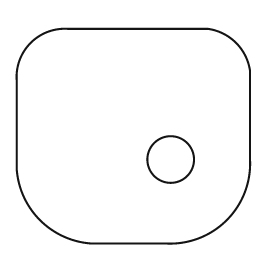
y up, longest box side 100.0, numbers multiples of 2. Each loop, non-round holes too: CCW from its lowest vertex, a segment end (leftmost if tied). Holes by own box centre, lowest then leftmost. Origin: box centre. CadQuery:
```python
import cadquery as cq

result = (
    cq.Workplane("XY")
    .moveTo(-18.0, -46.0)
    .lineTo(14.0, -46.0)
    .threePointArc((40.0, -36.0), (50.0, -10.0))
    .lineTo(50.0, 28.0)
    .threePointArc((44.0, 40.0), (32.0, 46.0))
    .lineTo(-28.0, 46.0)
    .threePointArc((-44.0, 40.0), (-50.0, 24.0))
    .lineTo(-50.0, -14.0)
    .threePointArc((-40.0, -36.0), (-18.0, -46.0))
    .close()
    .moveTo(16.0, -10.0)
    .circle(10.0)
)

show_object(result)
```